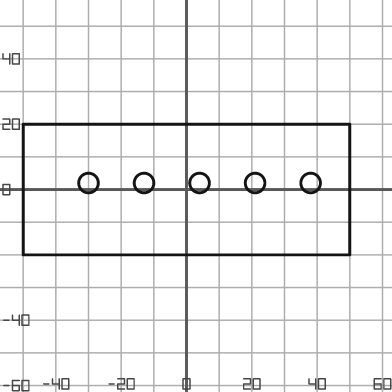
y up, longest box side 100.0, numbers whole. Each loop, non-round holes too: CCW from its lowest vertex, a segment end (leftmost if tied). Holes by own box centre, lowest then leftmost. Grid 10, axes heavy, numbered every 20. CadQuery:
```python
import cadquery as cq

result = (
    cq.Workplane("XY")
    .moveTo(-50.0, -20.0)
    .lineTo(50.0, -20.0)
    .lineTo(50.0, 20.0)
    .lineTo(-50.0, 20.0)
    .close()
    .moveTo(-30.0, 2.0)
    .circle(3.0)
    .moveTo(-13.0, 2.0)
    .circle(3.0)
    .moveTo(4.0, 2.0)
    .circle(3.0)
    .moveTo(21.0, 2.0)
    .circle(3.0)
    .moveTo(38.0, 2.0)
    .circle(3.0)
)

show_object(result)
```